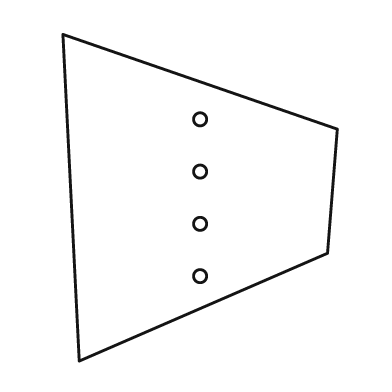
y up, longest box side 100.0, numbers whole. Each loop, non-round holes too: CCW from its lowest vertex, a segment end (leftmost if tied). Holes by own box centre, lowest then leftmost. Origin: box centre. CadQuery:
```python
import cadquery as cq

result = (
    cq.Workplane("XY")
    .moveTo(-37.0, -50.0)
    .lineTo(39.0, -17.0)
    .lineTo(42.0, 21.0)
    .lineTo(-42.0, 50.0)
    .close()
    .moveTo(0.0, -24.0)
    .circle(2.0)
    .moveTo(0.0, -8.0)
    .circle(2.0)
    .moveTo(0.0, 8.0)
    .circle(2.0)
    .moveTo(0.0, 24.0)
    .circle(2.0)
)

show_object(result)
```